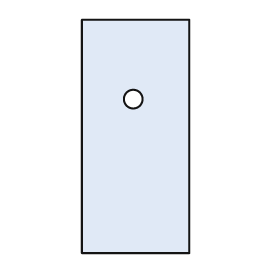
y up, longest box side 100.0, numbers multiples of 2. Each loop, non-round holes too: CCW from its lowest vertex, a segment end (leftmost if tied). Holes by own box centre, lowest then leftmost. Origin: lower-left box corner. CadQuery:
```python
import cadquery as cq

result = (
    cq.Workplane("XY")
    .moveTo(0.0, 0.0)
    .lineTo(46.0, 0.0)
    .lineTo(46.0, 100.0)
    .lineTo(0.0, 100.0)
    .close()
    .moveTo(22.0, 66.0)
    .circle(4.0)
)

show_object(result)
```